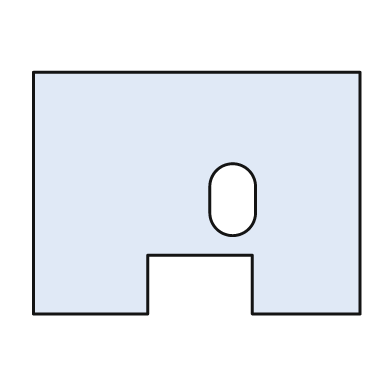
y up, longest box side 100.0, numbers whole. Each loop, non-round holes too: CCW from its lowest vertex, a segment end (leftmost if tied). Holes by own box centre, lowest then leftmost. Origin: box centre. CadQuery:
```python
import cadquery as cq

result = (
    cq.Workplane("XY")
    .moveTo(-50.0, -37.0)
    .lineTo(-15.0, -37.0)
    .lineTo(-15.0, -19.0)
    .lineTo(17.0, -19.0)
    .lineTo(17.0, -37.0)
    .lineTo(50.0, -37.0)
    .lineTo(50.0, 37.0)
    .lineTo(-50.0, 37.0)
    .close()
    .moveTo(4.0, -6.0)
    .threePointArc((11.0, -13.0), (18.0, -6.0))
    .lineTo(18.0, 2.0)
    .threePointArc((11.0, 9.0), (4.0, 2.0))
    .close()
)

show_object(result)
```